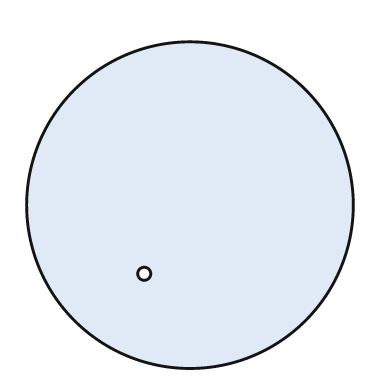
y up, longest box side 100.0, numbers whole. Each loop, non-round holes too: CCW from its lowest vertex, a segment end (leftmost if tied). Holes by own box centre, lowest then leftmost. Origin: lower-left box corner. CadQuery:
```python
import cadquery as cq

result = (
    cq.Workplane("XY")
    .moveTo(50.0, 50.0)
    .circle(50.0)
    .moveTo(36.0, 29.0)
    .circle(2.0)
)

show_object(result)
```